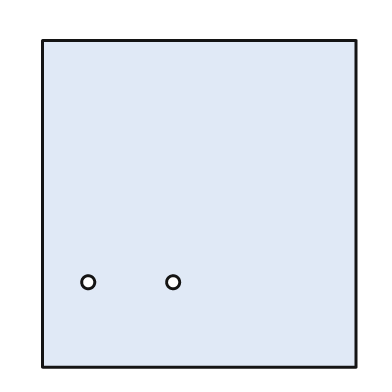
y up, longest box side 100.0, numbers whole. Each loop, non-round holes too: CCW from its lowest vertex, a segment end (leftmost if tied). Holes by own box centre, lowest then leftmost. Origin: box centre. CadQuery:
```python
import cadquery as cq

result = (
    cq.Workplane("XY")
    .moveTo(-48.0, -50.0)
    .lineTo(48.0, -50.0)
    .lineTo(48.0, 50.0)
    .lineTo(-48.0, 50.0)
    .close()
    .moveTo(-34.0, -24.0)
    .circle(2.0)
    .moveTo(-8.0, -24.0)
    .circle(2.0)
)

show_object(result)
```